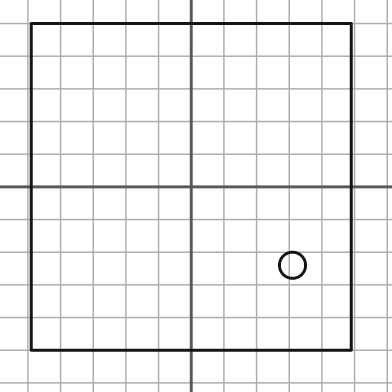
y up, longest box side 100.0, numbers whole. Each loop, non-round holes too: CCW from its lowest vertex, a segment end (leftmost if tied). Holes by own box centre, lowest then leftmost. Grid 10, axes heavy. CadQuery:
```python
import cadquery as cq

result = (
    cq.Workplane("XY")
    .moveTo(-49.0, -50.0)
    .lineTo(49.0, -50.0)
    .lineTo(49.0, 50.0)
    .lineTo(-49.0, 50.0)
    .close()
    .moveTo(31.0, -24.0)
    .circle(4.0)
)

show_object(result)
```